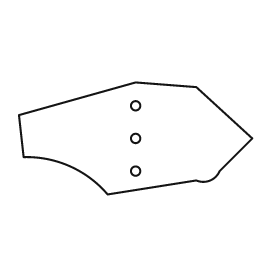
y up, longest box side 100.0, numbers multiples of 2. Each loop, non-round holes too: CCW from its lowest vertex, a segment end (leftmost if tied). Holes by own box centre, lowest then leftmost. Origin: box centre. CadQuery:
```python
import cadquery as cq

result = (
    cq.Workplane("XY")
    .moveTo(-12.0, -24.0)
    .lineTo(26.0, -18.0)
    .threePointArc((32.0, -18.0), (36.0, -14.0))
    .lineTo(50.0, 0.0)
    .lineTo(26.0, 22.0)
    .lineTo(0.0, 24.0)
    .lineTo(-50.0, 10.0)
    .lineTo(-48.0, -8.0)
    .threePointArc((-28.0, -12.0), (-12.0, -24.0))
    .close()
    .moveTo(0.0, -14.0)
    .circle(2.0)
    .moveTo(0.0, 0.0)
    .circle(2.0)
    .moveTo(0.0, 14.0)
    .circle(2.0)
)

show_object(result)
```